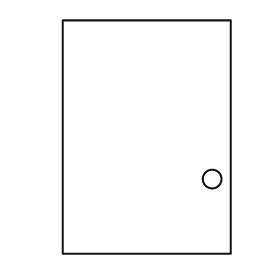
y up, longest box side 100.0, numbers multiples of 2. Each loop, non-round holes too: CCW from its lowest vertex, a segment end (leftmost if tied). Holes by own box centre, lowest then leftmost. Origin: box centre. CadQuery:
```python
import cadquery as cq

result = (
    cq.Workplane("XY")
    .moveTo(-36.0, -50.0)
    .lineTo(36.0, -50.0)
    .lineTo(36.0, 50.0)
    .lineTo(-36.0, 50.0)
    .close()
    .moveTo(28.0, -18.0)
    .circle(4.0)
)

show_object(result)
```